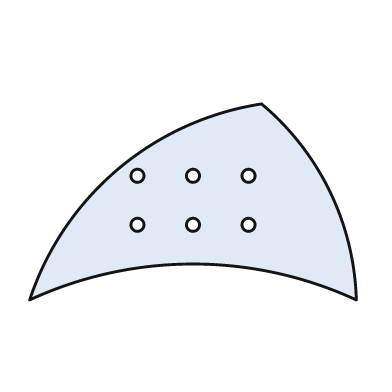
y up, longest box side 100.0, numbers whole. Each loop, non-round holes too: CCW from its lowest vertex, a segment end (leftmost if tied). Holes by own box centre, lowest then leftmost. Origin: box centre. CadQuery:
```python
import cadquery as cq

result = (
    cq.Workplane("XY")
    .moveTo(-50.0, -30.0)
    .threePointArc((0.0, -19.0), (50.0, -30.0))
    .threePointArc((42.0, 3.0), (21.0, 30.0))
    .threePointArc((-23.0, 10.0), (-50.0, -30.0))
    .close()
    .moveTo(-17.0, -7.0)
    .circle(2.0)
    .moveTo(0.0, -7.0)
    .circle(2.0)
    .moveTo(17.0, -7.0)
    .circle(2.0)
    .moveTo(-17.0, 8.0)
    .circle(2.0)
    .moveTo(0.0, 8.0)
    .circle(2.0)
    .moveTo(17.0, 8.0)
    .circle(2.0)
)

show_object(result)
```